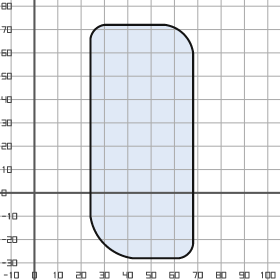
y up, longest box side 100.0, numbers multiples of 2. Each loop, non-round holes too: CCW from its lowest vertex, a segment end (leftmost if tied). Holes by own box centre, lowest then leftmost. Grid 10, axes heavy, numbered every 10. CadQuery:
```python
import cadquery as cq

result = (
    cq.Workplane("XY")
    .moveTo(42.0, -28.0)
    .lineTo(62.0, -28.0)
    .threePointArc((66.0, -26.0), (68.0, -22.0))
    .lineTo(68.0, 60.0)
    .threePointArc((64.0, 68.0), (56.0, 72.0))
    .lineTo(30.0, 72.0)
    .threePointArc((26.0, 70.0), (24.0, 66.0))
    .lineTo(24.0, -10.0)
    .threePointArc((30.0, -22.0), (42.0, -28.0))
    .close()
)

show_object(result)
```